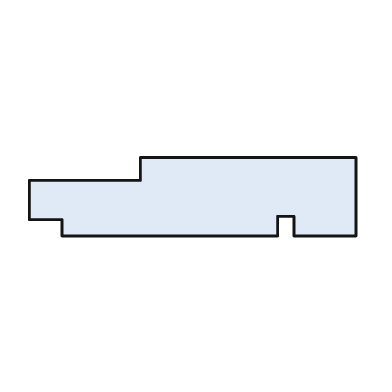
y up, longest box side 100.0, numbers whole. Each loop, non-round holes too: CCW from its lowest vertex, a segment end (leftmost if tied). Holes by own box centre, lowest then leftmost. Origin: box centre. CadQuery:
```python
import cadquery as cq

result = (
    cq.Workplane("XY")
    .moveTo(-40.0, -12.0)
    .lineTo(26.0, -12.0)
    .lineTo(26.0, -6.0)
    .lineTo(31.0, -6.0)
    .lineTo(31.0, -12.0)
    .lineTo(50.0, -12.0)
    .lineTo(50.0, 12.0)
    .lineTo(-16.0, 12.0)
    .lineTo(-16.0, 5.0)
    .lineTo(-50.0, 5.0)
    .lineTo(-50.0, -7.0)
    .lineTo(-40.0, -7.0)
    .close()
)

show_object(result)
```